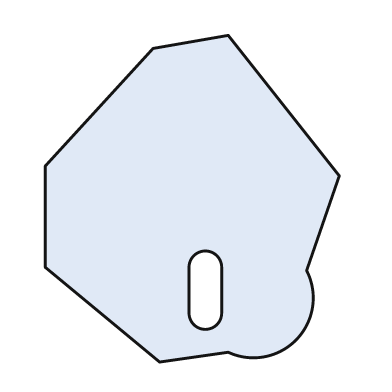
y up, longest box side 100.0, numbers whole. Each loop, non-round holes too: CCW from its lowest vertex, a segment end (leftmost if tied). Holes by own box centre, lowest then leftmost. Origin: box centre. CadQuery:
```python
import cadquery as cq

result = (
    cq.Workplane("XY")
    .moveTo(-10.0, -50.0)
    .lineTo(11.0, -47.0)
    .threePointArc((32.0, -43.0), (35.0, -22.0))
    .lineTo(45.0, 7.0)
    .lineTo(11.0, 50.0)
    .lineTo(-12.0, 46.0)
    .lineTo(-45.0, 10.0)
    .lineTo(-45.0, -21.0)
    .close()
    .moveTo(-1.0, -35.0)
    .threePointArc((4.0, -40.0), (9.0, -35.0))
    .lineTo(9.0, -21.0)
    .threePointArc((4.0, -16.0), (-1.0, -21.0))
    .close()
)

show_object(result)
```